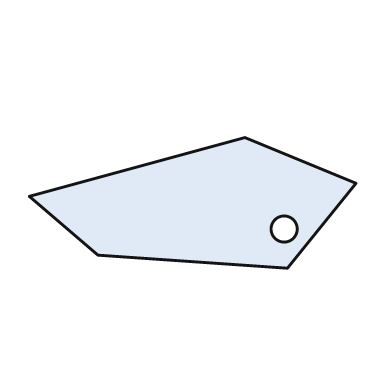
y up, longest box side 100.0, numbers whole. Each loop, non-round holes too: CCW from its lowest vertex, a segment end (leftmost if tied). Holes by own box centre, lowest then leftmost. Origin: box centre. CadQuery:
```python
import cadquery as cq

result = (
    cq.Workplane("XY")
    .moveTo(29.0, -20.0)
    .lineTo(50.0, 6.0)
    .lineTo(16.0, 20.0)
    .lineTo(-50.0, 2.0)
    .lineTo(-29.0, -16.0)
    .close()
    .moveTo(28.0, -8.0)
    .circle(4.0)
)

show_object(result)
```